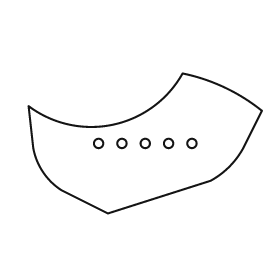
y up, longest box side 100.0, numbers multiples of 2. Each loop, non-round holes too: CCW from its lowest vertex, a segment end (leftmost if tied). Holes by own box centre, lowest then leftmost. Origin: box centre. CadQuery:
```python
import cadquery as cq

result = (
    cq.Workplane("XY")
    .moveTo(-16.0, -30.0)
    .lineTo(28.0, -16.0)
    .threePointArc((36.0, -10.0), (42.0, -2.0))
    .lineTo(50.0, 14.0)
    .threePointArc((34.0, 24.0), (16.0, 30.0))
    .threePointArc((-14.0, 8.0), (-50.0, 16.0))
    .lineTo(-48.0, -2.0)
    .threePointArc((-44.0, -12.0), (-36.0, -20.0))
    .close()
    .moveTo(-20.0, 0.0)
    .circle(2.0)
    .moveTo(-10.0, 0.0)
    .circle(2.0)
    .moveTo(0.0, 0.0)
    .circle(2.0)
    .moveTo(10.0, 0.0)
    .circle(2.0)
    .moveTo(20.0, 0.0)
    .circle(2.0)
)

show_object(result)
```